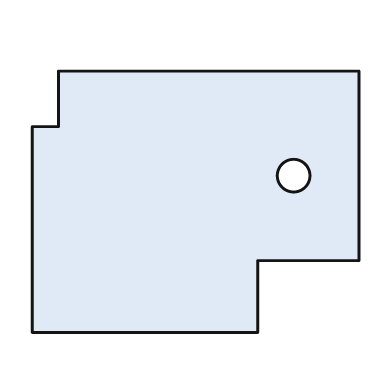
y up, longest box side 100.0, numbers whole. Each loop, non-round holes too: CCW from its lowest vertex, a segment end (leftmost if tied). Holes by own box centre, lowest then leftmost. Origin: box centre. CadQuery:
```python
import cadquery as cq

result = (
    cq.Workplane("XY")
    .moveTo(-50.0, -40.0)
    .lineTo(19.0, -40.0)
    .lineTo(19.0, -18.0)
    .lineTo(50.0, -18.0)
    .lineTo(50.0, 40.0)
    .lineTo(-42.0, 40.0)
    .lineTo(-42.0, 23.0)
    .lineTo(-50.0, 23.0)
    .close()
    .moveTo(30.0, 8.0)
    .circle(5.0)
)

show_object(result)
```